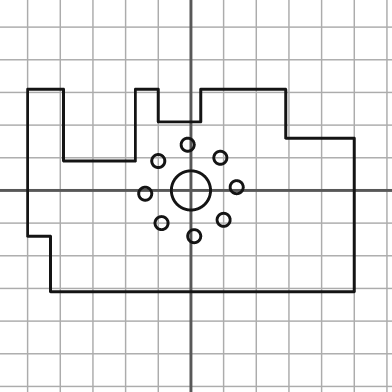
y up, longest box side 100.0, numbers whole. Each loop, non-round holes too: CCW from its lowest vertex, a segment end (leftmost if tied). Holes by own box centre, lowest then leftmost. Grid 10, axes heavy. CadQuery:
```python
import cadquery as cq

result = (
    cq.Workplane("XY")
    .moveTo(-43.0, -31.0)
    .lineTo(50.0, -31.0)
    .lineTo(50.0, 16.0)
    .lineTo(29.0, 16.0)
    .lineTo(29.0, 31.0)
    .lineTo(3.0, 31.0)
    .lineTo(3.0, 21.0)
    .lineTo(-10.0, 21.0)
    .lineTo(-10.0, 31.0)
    .lineTo(-17.0, 31.0)
    .lineTo(-17.0, 9.0)
    .lineTo(-39.0, 9.0)
    .lineTo(-39.0, 31.0)
    .lineTo(-50.0, 31.0)
    .lineTo(-50.0, -14.0)
    .lineTo(-43.0, -14.0)
    .close()
    .moveTo(1.0, -14.0)
    .circle(2.0)
    .moveTo(-9.0, -10.0)
    .circle(2.0)
    .moveTo(10.0, -9.0)
    .circle(2.0)
    .moveTo(-14.0, -1.0)
    .circle(2.0)
    .moveTo(0.0, 0.0)
    .circle(6.0)
    .moveTo(14.0, 1.0)
    .circle(2.0)
    .moveTo(-10.0, 9.0)
    .circle(2.0)
    .moveTo(9.0, 10.0)
    .circle(2.0)
    .moveTo(-1.0, 14.0)
    .circle(2.0)
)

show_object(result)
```